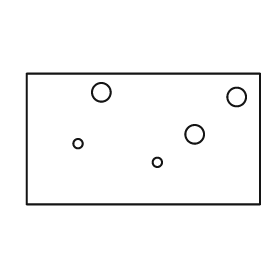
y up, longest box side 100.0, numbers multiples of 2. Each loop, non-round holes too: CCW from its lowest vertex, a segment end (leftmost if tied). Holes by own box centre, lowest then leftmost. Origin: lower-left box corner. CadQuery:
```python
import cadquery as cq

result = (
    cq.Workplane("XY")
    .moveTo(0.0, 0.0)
    .lineTo(100.0, 0.0)
    .lineTo(100.0, 56.0)
    .lineTo(0.0, 56.0)
    .close()
    .moveTo(56.0, 18.0)
    .circle(2.0)
    .moveTo(22.0, 26.0)
    .circle(2.0)
    .moveTo(72.0, 30.0)
    .circle(4.0)
    .moveTo(90.0, 46.0)
    .circle(4.0)
    .moveTo(32.0, 48.0)
    .circle(4.0)
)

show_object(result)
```